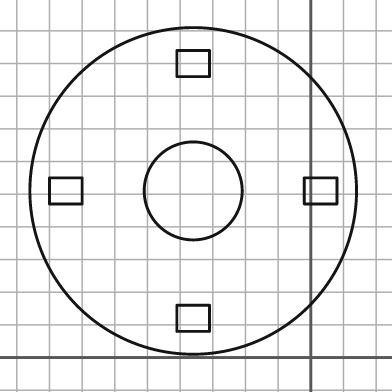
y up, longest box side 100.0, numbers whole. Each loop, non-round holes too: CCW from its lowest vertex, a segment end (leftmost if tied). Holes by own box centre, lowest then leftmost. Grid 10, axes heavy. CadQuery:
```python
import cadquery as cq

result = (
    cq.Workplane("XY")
    .moveTo(-36.0, 51.0)
    .circle(50.0)
    .moveTo(-41.0, 8.0)
    .lineTo(-31.0, 8.0)
    .lineTo(-31.0, 16.0)
    .lineTo(-41.0, 16.0)
    .close()
    .moveTo(-80.0, 47.0)
    .lineTo(-70.0, 47.0)
    .lineTo(-70.0, 55.0)
    .lineTo(-80.0, 55.0)
    .close()
    .moveTo(-36.0, 51.0)
    .circle(15.0)
    .moveTo(-2.0, 47.0)
    .lineTo(8.0, 47.0)
    .lineTo(8.0, 55.0)
    .lineTo(-2.0, 55.0)
    .close()
    .moveTo(-41.0, 86.0)
    .lineTo(-31.0, 86.0)
    .lineTo(-31.0, 94.0)
    .lineTo(-41.0, 94.0)
    .close()
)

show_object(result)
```